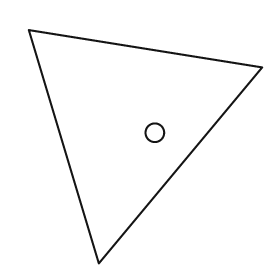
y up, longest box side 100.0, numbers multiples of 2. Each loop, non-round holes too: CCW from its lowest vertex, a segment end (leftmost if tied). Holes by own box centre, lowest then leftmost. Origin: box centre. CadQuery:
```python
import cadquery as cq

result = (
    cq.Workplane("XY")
    .moveTo(-20.0, -50.0)
    .lineTo(50.0, 34.0)
    .lineTo(-50.0, 50.0)
    .close()
    .moveTo(4.0, 6.0)
    .circle(4.0)
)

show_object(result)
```